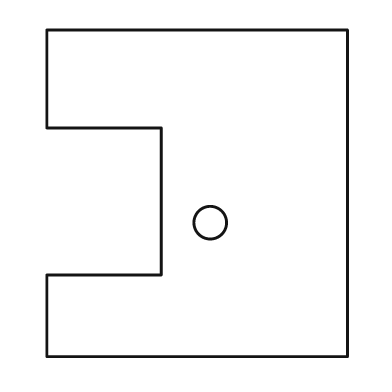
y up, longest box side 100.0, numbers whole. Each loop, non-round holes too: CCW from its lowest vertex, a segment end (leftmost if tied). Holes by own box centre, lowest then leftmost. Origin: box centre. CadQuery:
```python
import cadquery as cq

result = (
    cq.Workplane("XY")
    .moveTo(-46.0, -50.0)
    .lineTo(46.0, -50.0)
    .lineTo(46.0, 50.0)
    .lineTo(-46.0, 50.0)
    .lineTo(-46.0, 20.0)
    .lineTo(-11.0, 20.0)
    .lineTo(-11.0, -25.0)
    .lineTo(-46.0, -25.0)
    .close()
    .moveTo(4.0, -9.0)
    .circle(5.0)
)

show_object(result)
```